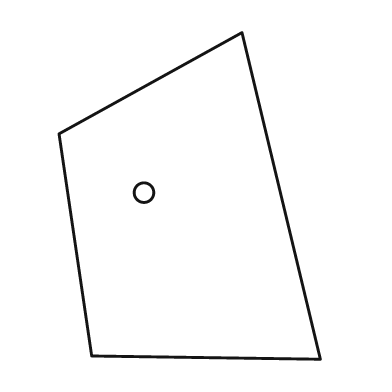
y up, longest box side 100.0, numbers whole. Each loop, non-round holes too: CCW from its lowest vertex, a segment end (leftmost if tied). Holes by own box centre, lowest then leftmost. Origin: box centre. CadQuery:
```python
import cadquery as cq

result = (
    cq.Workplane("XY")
    .moveTo(40.0, -50.0)
    .lineTo(16.0, 50.0)
    .lineTo(-40.0, 19.0)
    .lineTo(-30.0, -49.0)
    .close()
    .moveTo(-14.0, 1.0)
    .circle(3.0)
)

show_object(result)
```